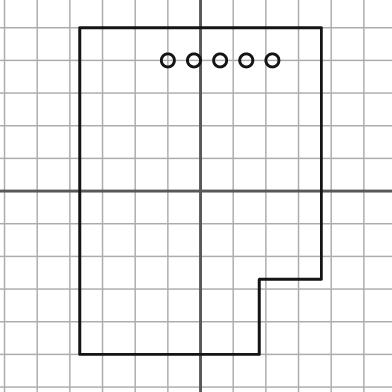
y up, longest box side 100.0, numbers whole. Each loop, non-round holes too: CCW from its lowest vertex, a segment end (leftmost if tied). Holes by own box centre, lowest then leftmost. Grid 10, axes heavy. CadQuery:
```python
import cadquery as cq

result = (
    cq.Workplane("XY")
    .moveTo(-37.0, -50.0)
    .lineTo(18.0, -50.0)
    .lineTo(18.0, -27.0)
    .lineTo(37.0, -27.0)
    .lineTo(37.0, 50.0)
    .lineTo(-37.0, 50.0)
    .close()
    .moveTo(-10.0, 40.0)
    .circle(2.0)
    .moveTo(-2.0, 40.0)
    .circle(2.0)
    .moveTo(6.0, 40.0)
    .circle(2.0)
    .moveTo(14.0, 40.0)
    .circle(2.0)
    .moveTo(22.0, 40.0)
    .circle(2.0)
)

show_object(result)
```